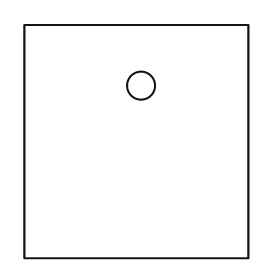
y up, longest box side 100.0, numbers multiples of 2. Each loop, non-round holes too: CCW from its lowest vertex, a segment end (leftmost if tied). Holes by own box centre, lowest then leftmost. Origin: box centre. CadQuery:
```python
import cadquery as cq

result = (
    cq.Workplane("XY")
    .moveTo(-48.0, -50.0)
    .lineTo(48.0, -50.0)
    .lineTo(48.0, 50.0)
    .lineTo(-48.0, 50.0)
    .close()
    .moveTo(2.0, 24.0)
    .circle(6.0)
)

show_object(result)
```